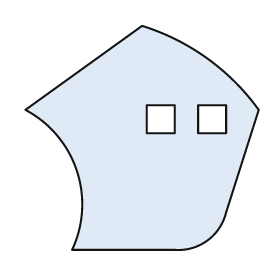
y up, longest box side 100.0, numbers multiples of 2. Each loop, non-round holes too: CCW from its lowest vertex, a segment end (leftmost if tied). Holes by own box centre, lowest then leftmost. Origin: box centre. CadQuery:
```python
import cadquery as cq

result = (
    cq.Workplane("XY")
    .moveTo(-30.0, -48.0)
    .lineTo(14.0, -48.0)
    .threePointArc((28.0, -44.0), (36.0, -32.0))
    .lineTo(50.0, 12.0)
    .threePointArc((28.0, 34.0), (0.0, 48.0))
    .lineTo(-50.0, 12.0)
    .threePointArc((-28.0, -14.0), (-30.0, -48.0))
    .close()
    .moveTo(2.0, 2.0)
    .lineTo(14.0, 2.0)
    .lineTo(14.0, 14.0)
    .lineTo(2.0, 14.0)
    .close()
    .moveTo(24.0, 2.0)
    .lineTo(36.0, 2.0)
    .lineTo(36.0, 14.0)
    .lineTo(24.0, 14.0)
    .close()
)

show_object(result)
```